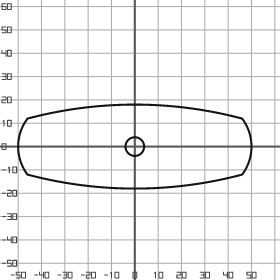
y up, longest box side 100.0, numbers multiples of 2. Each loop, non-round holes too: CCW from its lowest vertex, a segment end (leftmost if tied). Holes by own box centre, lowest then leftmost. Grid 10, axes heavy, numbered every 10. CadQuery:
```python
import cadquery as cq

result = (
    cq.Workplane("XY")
    .moveTo(-46.0, -12.0)
    .threePointArc((0.0, -18.0), (46.0, -12.0))
    .threePointArc((50.0, 0.0), (46.0, 12.0))
    .threePointArc((0.0, 18.0), (-46.0, 12.0))
    .threePointArc((-50.0, 0.0), (-46.0, -12.0))
    .close()
    .moveTo(0.0, 0.0)
    .circle(4.0)
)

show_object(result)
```